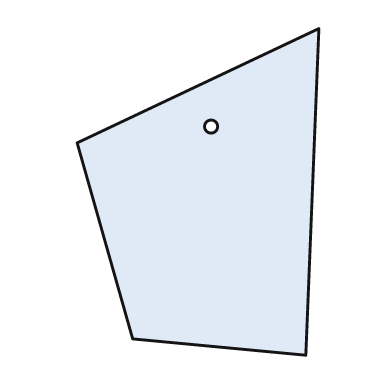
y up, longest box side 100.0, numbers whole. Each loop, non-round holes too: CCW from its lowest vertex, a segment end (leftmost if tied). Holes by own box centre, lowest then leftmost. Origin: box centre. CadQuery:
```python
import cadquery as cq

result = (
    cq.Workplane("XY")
    .moveTo(33.0, -50.0)
    .lineTo(37.0, 50.0)
    .lineTo(-37.0, 15.0)
    .lineTo(-20.0, -45.0)
    .close()
    .moveTo(4.0, 20.0)
    .circle(2.0)
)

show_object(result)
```